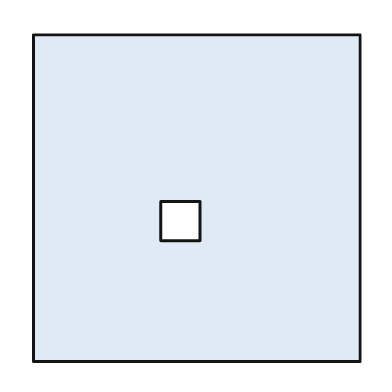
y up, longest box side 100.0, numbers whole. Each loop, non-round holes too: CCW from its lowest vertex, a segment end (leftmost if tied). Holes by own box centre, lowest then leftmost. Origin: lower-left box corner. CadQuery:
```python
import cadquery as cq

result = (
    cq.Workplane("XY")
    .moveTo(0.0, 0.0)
    .lineTo(100.0, 0.0)
    .lineTo(100.0, 100.0)
    .lineTo(0.0, 100.0)
    .close()
    .moveTo(39.0, 37.0)
    .lineTo(51.0, 37.0)
    .lineTo(51.0, 49.0)
    .lineTo(39.0, 49.0)
    .close()
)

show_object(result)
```